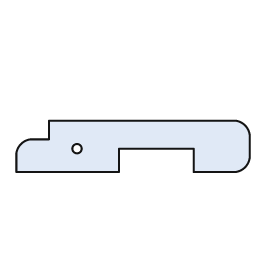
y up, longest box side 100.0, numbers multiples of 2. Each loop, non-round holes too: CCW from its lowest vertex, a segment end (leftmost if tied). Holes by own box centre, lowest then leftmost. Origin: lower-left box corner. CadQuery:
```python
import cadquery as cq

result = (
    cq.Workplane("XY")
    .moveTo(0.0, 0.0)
    .lineTo(44.0, 0.0)
    .lineTo(44.0, 10.0)
    .lineTo(76.0, 10.0)
    .lineTo(76.0, 0.0)
    .lineTo(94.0, 0.0)
    .threePointArc((98.0, 2.0), (100.0, 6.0))
    .lineTo(100.0, 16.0)
    .threePointArc((98.0, 20.0), (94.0, 22.0))
    .lineTo(14.0, 22.0)
    .lineTo(14.0, 14.0)
    .lineTo(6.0, 14.0)
    .threePointArc((2.0, 12.0), (0.0, 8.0))
    .close()
    .moveTo(26.0, 10.0)
    .circle(2.0)
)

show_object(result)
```